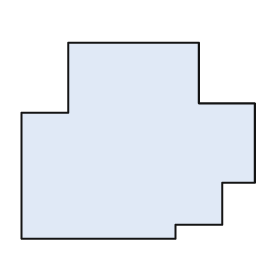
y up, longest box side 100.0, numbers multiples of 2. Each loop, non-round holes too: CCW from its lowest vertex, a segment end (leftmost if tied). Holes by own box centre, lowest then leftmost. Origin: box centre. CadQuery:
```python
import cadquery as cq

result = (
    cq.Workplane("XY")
    .moveTo(-50.0, -42.0)
    .lineTo(16.0, -42.0)
    .lineTo(16.0, -36.0)
    .lineTo(36.0, -36.0)
    .lineTo(36.0, -18.0)
    .lineTo(50.0, -18.0)
    .lineTo(50.0, 16.0)
    .lineTo(26.0, 16.0)
    .lineTo(26.0, 42.0)
    .lineTo(-30.0, 42.0)
    .lineTo(-30.0, 12.0)
    .lineTo(-50.0, 12.0)
    .close()
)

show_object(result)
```